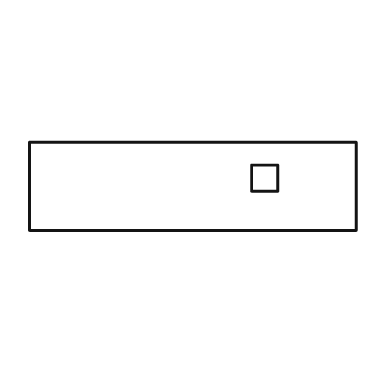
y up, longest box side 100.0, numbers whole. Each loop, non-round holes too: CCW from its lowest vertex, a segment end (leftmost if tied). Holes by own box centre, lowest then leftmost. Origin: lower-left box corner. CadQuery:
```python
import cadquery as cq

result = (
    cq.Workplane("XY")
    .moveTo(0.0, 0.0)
    .lineTo(100.0, 0.0)
    .lineTo(100.0, 27.0)
    .lineTo(0.0, 27.0)
    .close()
    .moveTo(68.0, 12.0)
    .lineTo(76.0, 12.0)
    .lineTo(76.0, 20.0)
    .lineTo(68.0, 20.0)
    .close()
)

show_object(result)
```